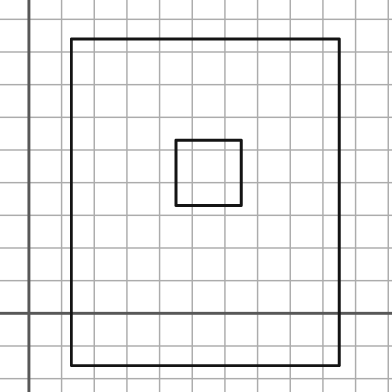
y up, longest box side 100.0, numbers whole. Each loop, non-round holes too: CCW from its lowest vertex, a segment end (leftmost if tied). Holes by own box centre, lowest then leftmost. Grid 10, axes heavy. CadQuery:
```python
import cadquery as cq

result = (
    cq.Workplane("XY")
    .moveTo(13.0, -16.0)
    .lineTo(95.0, -16.0)
    .lineTo(95.0, 84.0)
    .lineTo(13.0, 84.0)
    .close()
    .moveTo(45.0, 33.0)
    .lineTo(65.0, 33.0)
    .lineTo(65.0, 53.0)
    .lineTo(45.0, 53.0)
    .close()
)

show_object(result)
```